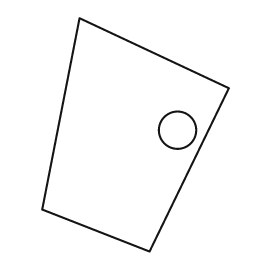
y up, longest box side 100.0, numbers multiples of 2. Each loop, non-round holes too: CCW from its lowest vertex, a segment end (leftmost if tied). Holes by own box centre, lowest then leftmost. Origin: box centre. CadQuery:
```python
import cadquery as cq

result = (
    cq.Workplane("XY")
    .moveTo(6.0, -50.0)
    .lineTo(40.0, 20.0)
    .lineTo(-24.0, 50.0)
    .lineTo(-40.0, -32.0)
    .close()
    .moveTo(18.0, 2.0)
    .circle(8.0)
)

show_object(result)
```